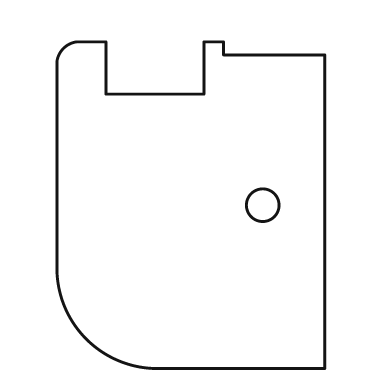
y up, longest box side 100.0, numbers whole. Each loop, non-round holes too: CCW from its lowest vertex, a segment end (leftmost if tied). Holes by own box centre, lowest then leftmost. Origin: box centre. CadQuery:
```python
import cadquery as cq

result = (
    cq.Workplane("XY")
    .moveTo(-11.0, -50.0)
    .lineTo(41.0, -50.0)
    .lineTo(41.0, 46.0)
    .lineTo(10.0, 46.0)
    .lineTo(10.0, 50.0)
    .lineTo(4.0, 50.0)
    .lineTo(4.0, 34.0)
    .lineTo(-26.0, 34.0)
    .lineTo(-26.0, 50.0)
    .lineTo(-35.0, 50.0)
    .threePointArc((-39.0, 48.0), (-41.0, 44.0))
    .lineTo(-41.0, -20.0)
    .threePointArc((-32.0, -41.0), (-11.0, -50.0))
    .close()
    .moveTo(22.0, 0.0)
    .circle(5.0)
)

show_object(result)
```